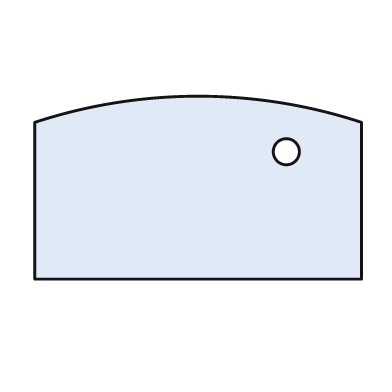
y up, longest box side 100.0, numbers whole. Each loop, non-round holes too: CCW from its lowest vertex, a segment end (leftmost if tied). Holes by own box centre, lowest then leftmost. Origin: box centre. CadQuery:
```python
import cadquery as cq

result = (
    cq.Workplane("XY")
    .moveTo(-50.0, -28.0)
    .lineTo(50.0, -28.0)
    .lineTo(50.0, 20.0)
    .threePointArc((0.0, 28.0), (-50.0, 20.0))
    .close()
    .moveTo(27.0, 11.0)
    .circle(4.0)
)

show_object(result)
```